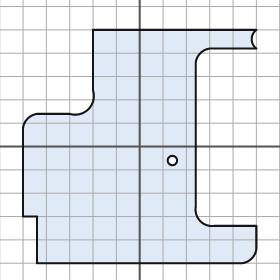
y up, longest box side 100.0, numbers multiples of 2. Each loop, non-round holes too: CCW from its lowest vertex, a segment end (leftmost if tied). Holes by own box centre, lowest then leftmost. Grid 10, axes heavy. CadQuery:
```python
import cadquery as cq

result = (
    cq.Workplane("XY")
    .moveTo(-44.0, -50.0)
    .lineTo(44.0, -50.0)
    .threePointArc((48.0, -48.0), (50.0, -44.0))
    .lineTo(50.0, -34.0)
    .lineTo(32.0, -34.0)
    .threePointArc((26.0, -32.0), (24.0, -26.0))
    .lineTo(24.0, 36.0)
    .threePointArc((26.0, 40.0), (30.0, 42.0))
    .lineTo(50.0, 42.0)
    .threePointArc((48.0, 46.0), (50.0, 50.0))
    .lineTo(-20.0, 50.0)
    .lineTo(-20.0, 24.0)
    .threePointArc((-22.0, 16.0), (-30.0, 14.0))
    .lineTo(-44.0, 14.0)
    .threePointArc((-48.0, 12.0), (-50.0, 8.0))
    .lineTo(-50.0, -30.0)
    .lineTo(-44.0, -30.0)
    .close()
    .moveTo(14.0, -6.0)
    .circle(2.0)
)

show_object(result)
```